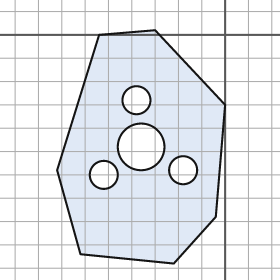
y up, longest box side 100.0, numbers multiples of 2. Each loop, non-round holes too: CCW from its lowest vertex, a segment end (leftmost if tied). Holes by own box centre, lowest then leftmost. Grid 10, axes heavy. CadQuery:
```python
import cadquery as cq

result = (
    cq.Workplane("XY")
    .moveTo(-22.0, -98.0)
    .lineTo(-4.0, -78.0)
    .lineTo(0.0, -30.0)
    .lineTo(-30.0, 2.0)
    .lineTo(-54.0, 0.0)
    .lineTo(-72.0, -58.0)
    .lineTo(-62.0, -94.0)
    .close()
    .moveTo(-52.0, -60.0)
    .circle(6.0)
    .moveTo(-18.0, -58.0)
    .circle(6.0)
    .moveTo(-36.0, -48.0)
    .circle(10.0)
    .moveTo(-38.0, -28.0)
    .circle(6.0)
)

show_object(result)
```